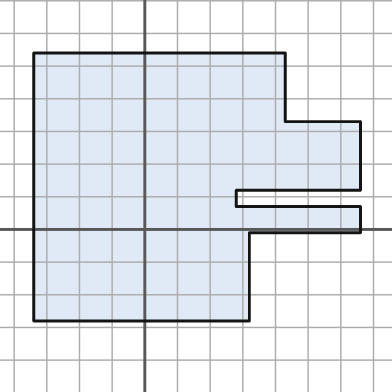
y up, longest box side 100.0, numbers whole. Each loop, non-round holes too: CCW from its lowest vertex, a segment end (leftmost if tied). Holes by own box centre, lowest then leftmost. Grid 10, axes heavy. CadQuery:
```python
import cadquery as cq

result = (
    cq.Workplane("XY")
    .moveTo(-34.0, -28.0)
    .lineTo(32.0, -28.0)
    .lineTo(32.0, -1.0)
    .lineTo(66.0, -1.0)
    .lineTo(66.0, 7.0)
    .lineTo(28.0, 7.0)
    .lineTo(28.0, 12.0)
    .lineTo(66.0, 12.0)
    .lineTo(66.0, 33.0)
    .lineTo(43.0, 33.0)
    .lineTo(43.0, 54.0)
    .lineTo(-34.0, 54.0)
    .close()
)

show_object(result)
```